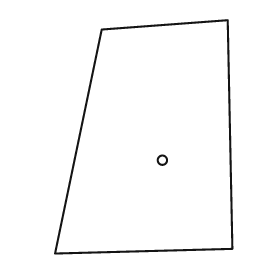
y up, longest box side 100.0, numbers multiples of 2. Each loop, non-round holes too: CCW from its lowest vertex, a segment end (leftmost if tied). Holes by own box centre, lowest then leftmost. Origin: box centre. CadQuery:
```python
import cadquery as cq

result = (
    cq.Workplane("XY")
    .moveTo(-38.0, -50.0)
    .lineTo(38.0, -48.0)
    .lineTo(36.0, 50.0)
    .lineTo(-18.0, 46.0)
    .close()
    .moveTo(8.0, -10.0)
    .circle(2.0)
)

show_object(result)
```